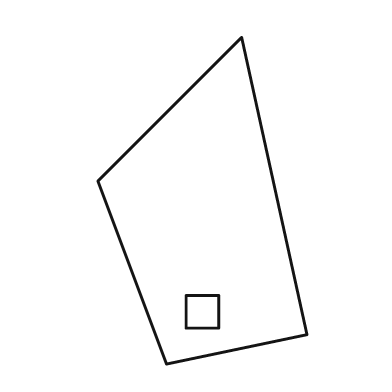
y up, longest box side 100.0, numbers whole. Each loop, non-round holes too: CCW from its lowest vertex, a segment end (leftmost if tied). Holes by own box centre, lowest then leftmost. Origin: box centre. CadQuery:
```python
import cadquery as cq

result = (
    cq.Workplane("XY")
    .moveTo(-11.0, -50.0)
    .lineTo(32.0, -41.0)
    .lineTo(12.0, 50.0)
    .lineTo(-32.0, 6.0)
    .close()
    .moveTo(-5.0, -39.0)
    .lineTo(5.0, -39.0)
    .lineTo(5.0, -29.0)
    .lineTo(-5.0, -29.0)
    .close()
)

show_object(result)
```